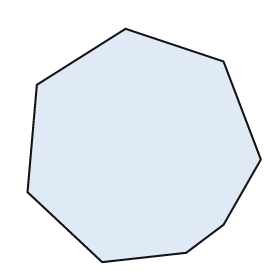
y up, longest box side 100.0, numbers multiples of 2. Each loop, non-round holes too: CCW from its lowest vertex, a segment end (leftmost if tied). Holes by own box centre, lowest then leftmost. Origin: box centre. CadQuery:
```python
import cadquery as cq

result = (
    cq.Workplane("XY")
    .moveTo(-18.0, -50.0)
    .lineTo(18.0, -46.0)
    .lineTo(34.0, -34.0)
    .lineTo(50.0, -6.0)
    .lineTo(34.0, 36.0)
    .lineTo(-8.0, 50.0)
    .lineTo(-46.0, 26.0)
    .lineTo(-50.0, -20.0)
    .close()
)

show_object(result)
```